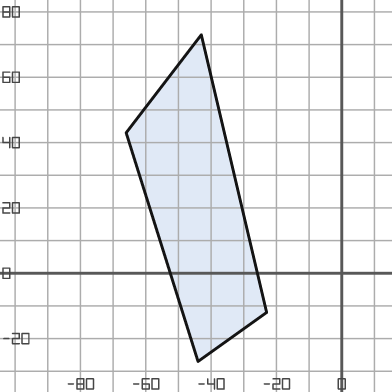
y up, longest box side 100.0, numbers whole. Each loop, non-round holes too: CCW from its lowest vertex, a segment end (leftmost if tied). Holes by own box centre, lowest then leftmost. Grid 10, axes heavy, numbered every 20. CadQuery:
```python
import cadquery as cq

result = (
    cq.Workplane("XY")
    .moveTo(-44.0, -27.0)
    .lineTo(-23.0, -12.0)
    .lineTo(-43.0, 73.0)
    .lineTo(-66.0, 43.0)
    .close()
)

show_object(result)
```